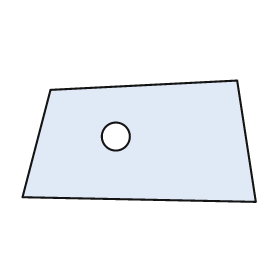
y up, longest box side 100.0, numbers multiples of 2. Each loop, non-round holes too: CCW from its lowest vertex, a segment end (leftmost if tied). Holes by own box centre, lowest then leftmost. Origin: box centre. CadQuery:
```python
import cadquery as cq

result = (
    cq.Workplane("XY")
    .moveTo(50.0, -26.0)
    .lineTo(42.0, 26.0)
    .lineTo(-38.0, 22.0)
    .lineTo(-50.0, -24.0)
    .close()
    .moveTo(-10.0, 2.0)
    .circle(6.0)
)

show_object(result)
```